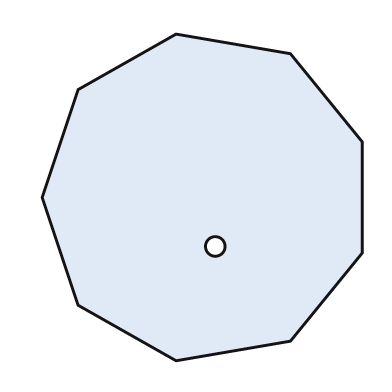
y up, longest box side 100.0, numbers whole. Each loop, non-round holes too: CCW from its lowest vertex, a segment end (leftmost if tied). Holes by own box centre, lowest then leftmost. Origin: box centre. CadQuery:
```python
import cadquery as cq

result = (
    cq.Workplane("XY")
    .moveTo(-8.0, -50.0)
    .lineTo(27.0, -44.0)
    .lineTo(49.0, -17.0)
    .lineTo(49.0, 17.0)
    .lineTo(27.0, 44.0)
    .lineTo(-8.0, 50.0)
    .lineTo(-38.0, 33.0)
    .lineTo(-49.0, 0.0)
    .lineTo(-38.0, -33.0)
    .close()
    .moveTo(4.0, -15.0)
    .circle(3.0)
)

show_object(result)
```